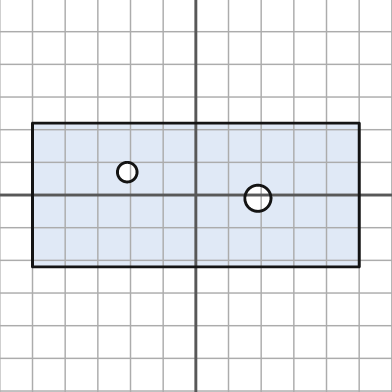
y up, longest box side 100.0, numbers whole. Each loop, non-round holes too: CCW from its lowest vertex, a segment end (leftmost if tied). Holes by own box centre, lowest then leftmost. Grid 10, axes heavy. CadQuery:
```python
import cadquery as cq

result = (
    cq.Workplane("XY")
    .moveTo(-50.0, -22.0)
    .lineTo(50.0, -22.0)
    .lineTo(50.0, 22.0)
    .lineTo(-50.0, 22.0)
    .close()
    .moveTo(19.0, -1.0)
    .circle(4.0)
    .moveTo(-21.0, 7.0)
    .circle(3.0)
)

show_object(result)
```